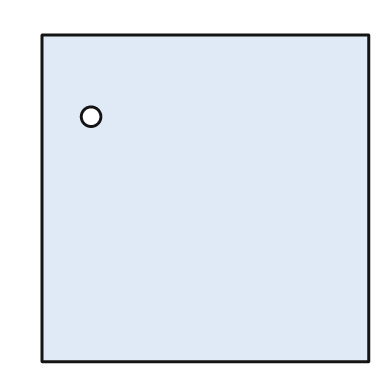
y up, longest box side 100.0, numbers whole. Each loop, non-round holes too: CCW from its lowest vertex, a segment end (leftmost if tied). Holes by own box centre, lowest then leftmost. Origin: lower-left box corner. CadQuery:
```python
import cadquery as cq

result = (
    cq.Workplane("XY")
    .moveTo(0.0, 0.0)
    .lineTo(100.0, 0.0)
    .lineTo(100.0, 100.0)
    .lineTo(0.0, 100.0)
    .close()
    .moveTo(15.0, 75.0)
    .circle(3.0)
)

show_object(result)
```